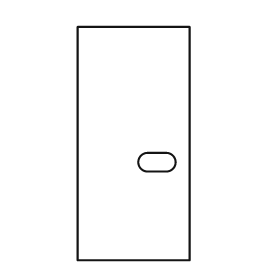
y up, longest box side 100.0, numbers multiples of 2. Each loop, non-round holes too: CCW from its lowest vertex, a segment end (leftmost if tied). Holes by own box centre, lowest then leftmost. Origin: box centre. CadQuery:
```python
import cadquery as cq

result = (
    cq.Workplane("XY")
    .moveTo(-24.0, -50.0)
    .lineTo(24.0, -50.0)
    .lineTo(24.0, 50.0)
    .lineTo(-24.0, 50.0)
    .close()
    .moveTo(6.0, -12.0)
    .lineTo(14.0, -12.0)
    .threePointArc((18.0, -8.0), (14.0, -4.0))
    .lineTo(6.0, -4.0)
    .threePointArc((2.0, -8.0), (6.0, -12.0))
    .close()
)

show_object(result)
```